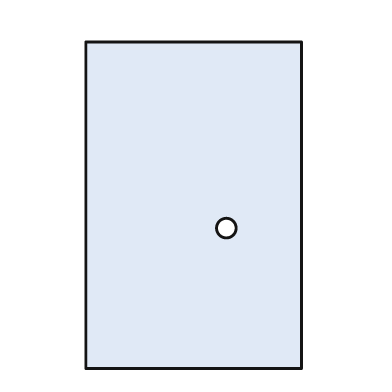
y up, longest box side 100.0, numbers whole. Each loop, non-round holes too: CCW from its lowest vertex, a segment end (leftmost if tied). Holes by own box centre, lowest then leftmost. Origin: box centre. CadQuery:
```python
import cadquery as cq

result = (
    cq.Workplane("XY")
    .moveTo(-33.0, -50.0)
    .lineTo(33.0, -50.0)
    .lineTo(33.0, 50.0)
    .lineTo(-33.0, 50.0)
    .close()
    .moveTo(10.0, -7.0)
    .circle(3.0)
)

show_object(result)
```